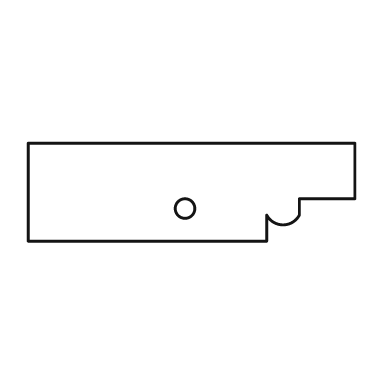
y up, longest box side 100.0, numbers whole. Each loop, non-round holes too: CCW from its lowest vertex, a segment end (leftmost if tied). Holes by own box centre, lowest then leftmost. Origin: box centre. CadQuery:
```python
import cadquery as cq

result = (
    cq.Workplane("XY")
    .moveTo(-50.0, -15.0)
    .lineTo(23.0, -15.0)
    .lineTo(23.0, -7.0)
    .threePointArc((28.0, -10.0), (33.0, -7.0))
    .lineTo(33.0, -2.0)
    .lineTo(50.0, -2.0)
    .lineTo(50.0, 15.0)
    .lineTo(-50.0, 15.0)
    .close()
    .moveTo(-2.0, -5.0)
    .circle(3.0)
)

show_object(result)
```